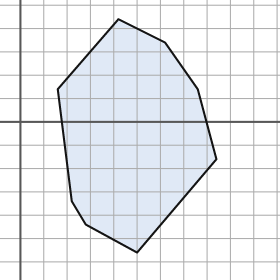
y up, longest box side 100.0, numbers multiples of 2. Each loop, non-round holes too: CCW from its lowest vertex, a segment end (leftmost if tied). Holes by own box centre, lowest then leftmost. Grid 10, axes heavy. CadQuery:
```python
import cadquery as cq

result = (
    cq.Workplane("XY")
    .moveTo(50.0, -56.0)
    .lineTo(84.0, -16.0)
    .lineTo(76.0, 14.0)
    .lineTo(62.0, 34.0)
    .lineTo(42.0, 44.0)
    .lineTo(16.0, 14.0)
    .lineTo(22.0, -34.0)
    .lineTo(28.0, -44.0)
    .close()
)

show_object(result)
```